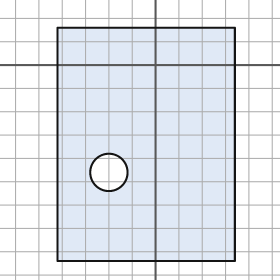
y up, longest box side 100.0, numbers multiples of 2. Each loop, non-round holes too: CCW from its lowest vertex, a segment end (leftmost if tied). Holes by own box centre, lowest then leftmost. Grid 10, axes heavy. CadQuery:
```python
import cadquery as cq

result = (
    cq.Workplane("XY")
    .moveTo(-42.0, -84.0)
    .lineTo(34.0, -84.0)
    .lineTo(34.0, 16.0)
    .lineTo(-42.0, 16.0)
    .close()
    .moveTo(-20.0, -46.0)
    .circle(8.0)
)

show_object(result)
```